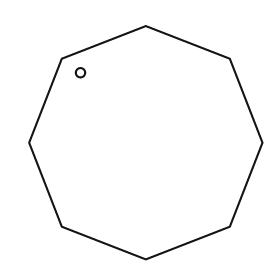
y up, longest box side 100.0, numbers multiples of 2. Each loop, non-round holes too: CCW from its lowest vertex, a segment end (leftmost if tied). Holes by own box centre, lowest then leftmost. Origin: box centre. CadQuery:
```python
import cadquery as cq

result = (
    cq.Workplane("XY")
    .moveTo(0.0, -50.0)
    .lineTo(36.0, -36.0)
    .lineTo(50.0, 0.0)
    .lineTo(36.0, 36.0)
    .lineTo(0.0, 50.0)
    .lineTo(-36.0, 36.0)
    .lineTo(-50.0, 0.0)
    .lineTo(-36.0, -36.0)
    .close()
    .moveTo(-28.0, 30.0)
    .circle(2.0)
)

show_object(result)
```